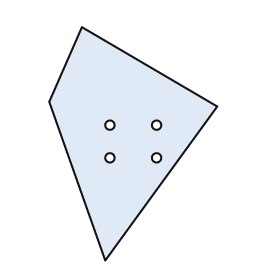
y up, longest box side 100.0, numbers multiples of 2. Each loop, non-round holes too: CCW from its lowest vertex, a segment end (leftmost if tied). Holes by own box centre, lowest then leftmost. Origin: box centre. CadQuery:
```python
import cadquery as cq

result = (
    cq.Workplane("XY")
    .moveTo(-12.0, -50.0)
    .lineTo(36.0, 16.0)
    .lineTo(-22.0, 50.0)
    .lineTo(-36.0, 18.0)
    .close()
    .moveTo(-10.0, -6.0)
    .circle(2.0)
    .moveTo(10.0, -6.0)
    .circle(2.0)
    .moveTo(-10.0, 8.0)
    .circle(2.0)
    .moveTo(10.0, 8.0)
    .circle(2.0)
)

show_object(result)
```